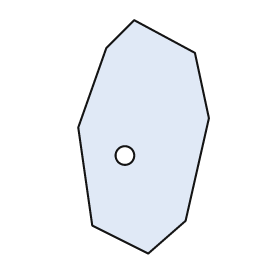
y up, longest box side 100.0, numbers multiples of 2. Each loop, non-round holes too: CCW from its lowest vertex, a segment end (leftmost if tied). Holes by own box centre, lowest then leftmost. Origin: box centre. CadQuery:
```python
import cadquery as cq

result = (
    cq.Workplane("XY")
    .moveTo(2.0, -50.0)
    .lineTo(18.0, -36.0)
    .lineTo(28.0, 8.0)
    .lineTo(22.0, 36.0)
    .lineTo(-4.0, 50.0)
    .lineTo(-16.0, 38.0)
    .lineTo(-28.0, 4.0)
    .lineTo(-22.0, -38.0)
    .close()
    .moveTo(-8.0, -8.0)
    .circle(4.0)
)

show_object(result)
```